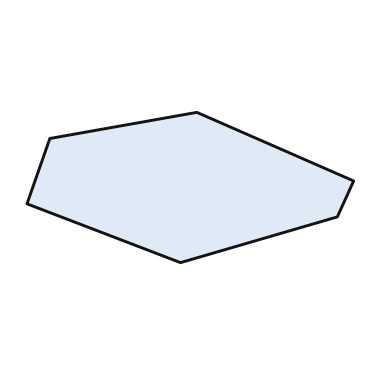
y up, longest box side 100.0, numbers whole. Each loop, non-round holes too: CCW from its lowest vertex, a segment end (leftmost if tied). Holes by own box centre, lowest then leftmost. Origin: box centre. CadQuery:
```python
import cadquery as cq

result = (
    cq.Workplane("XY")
    .moveTo(-3.0, -23.0)
    .lineTo(45.0, -9.0)
    .lineTo(50.0, 2.0)
    .lineTo(2.0, 23.0)
    .lineTo(-43.0, 15.0)
    .lineTo(-50.0, -5.0)
    .close()
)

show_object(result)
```